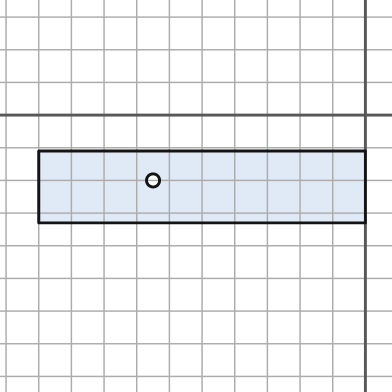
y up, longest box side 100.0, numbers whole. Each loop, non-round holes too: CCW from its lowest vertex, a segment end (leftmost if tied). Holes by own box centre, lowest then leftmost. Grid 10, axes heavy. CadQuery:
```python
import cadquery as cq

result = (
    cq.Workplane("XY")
    .moveTo(-100.0, -33.0)
    .lineTo(0.0, -33.0)
    .lineTo(0.0, -11.0)
    .lineTo(-100.0, -11.0)
    .close()
    .moveTo(-65.0, -20.0)
    .circle(2.0)
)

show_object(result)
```